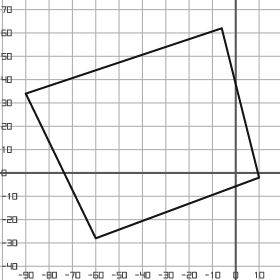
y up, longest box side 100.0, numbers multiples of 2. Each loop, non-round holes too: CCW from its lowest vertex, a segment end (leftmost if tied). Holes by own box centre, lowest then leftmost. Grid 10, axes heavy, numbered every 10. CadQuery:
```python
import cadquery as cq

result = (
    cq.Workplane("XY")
    .moveTo(-60.0, -28.0)
    .lineTo(10.0, -2.0)
    .lineTo(-6.0, 62.0)
    .lineTo(-90.0, 34.0)
    .close()
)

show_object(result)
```